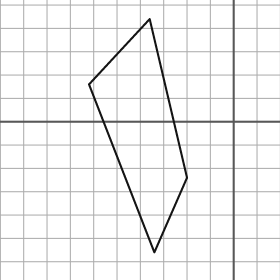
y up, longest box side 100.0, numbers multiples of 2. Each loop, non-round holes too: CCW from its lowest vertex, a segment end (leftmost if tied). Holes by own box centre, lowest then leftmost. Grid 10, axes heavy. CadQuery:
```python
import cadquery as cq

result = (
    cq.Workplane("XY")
    .moveTo(-34.0, -56.0)
    .lineTo(-20.0, -24.0)
    .lineTo(-36.0, 44.0)
    .lineTo(-62.0, 16.0)
    .close()
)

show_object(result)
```